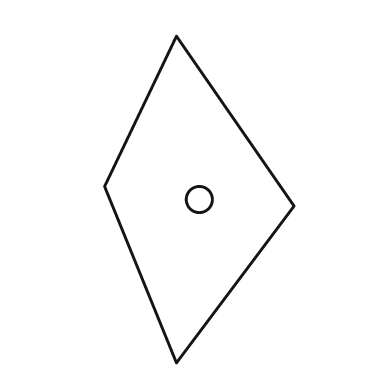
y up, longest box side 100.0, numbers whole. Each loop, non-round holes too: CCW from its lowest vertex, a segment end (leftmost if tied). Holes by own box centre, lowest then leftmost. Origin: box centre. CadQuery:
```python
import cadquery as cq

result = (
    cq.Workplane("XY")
    .moveTo(-7.0, -50.0)
    .lineTo(29.0, -2.0)
    .lineTo(-7.0, 50.0)
    .lineTo(-29.0, 4.0)
    .close()
    .moveTo(0.0, 0.0)
    .circle(4.0)
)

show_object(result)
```